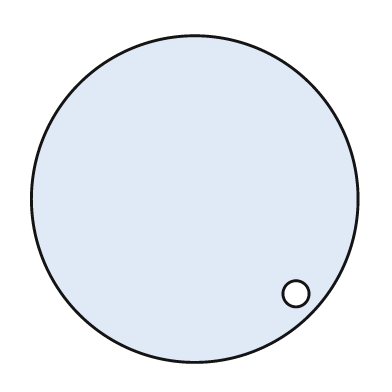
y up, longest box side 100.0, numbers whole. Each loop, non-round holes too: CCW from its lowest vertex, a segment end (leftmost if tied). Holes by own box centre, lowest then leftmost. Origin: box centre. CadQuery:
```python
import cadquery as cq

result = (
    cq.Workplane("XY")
    .moveTo(0.0, 0.0)
    .circle(50.0)
    .moveTo(31.0, -29.0)
    .circle(4.0)
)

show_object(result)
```